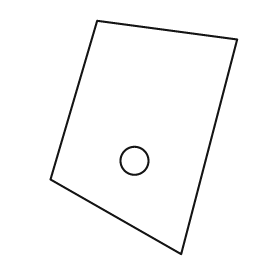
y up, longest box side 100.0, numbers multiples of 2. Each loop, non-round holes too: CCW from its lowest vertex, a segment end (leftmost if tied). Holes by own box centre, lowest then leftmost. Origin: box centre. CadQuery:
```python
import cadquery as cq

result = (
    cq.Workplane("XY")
    .moveTo(16.0, -50.0)
    .lineTo(40.0, 42.0)
    .lineTo(-20.0, 50.0)
    .lineTo(-40.0, -18.0)
    .close()
    .moveTo(-4.0, -10.0)
    .circle(6.0)
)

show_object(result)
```